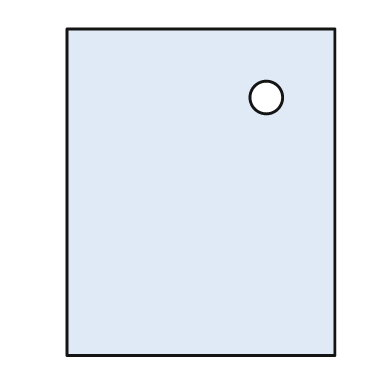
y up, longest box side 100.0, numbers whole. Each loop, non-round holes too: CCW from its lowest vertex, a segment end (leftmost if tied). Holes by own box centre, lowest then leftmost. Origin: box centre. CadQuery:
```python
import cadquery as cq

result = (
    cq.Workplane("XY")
    .moveTo(-41.0, -50.0)
    .lineTo(41.0, -50.0)
    .lineTo(41.0, 50.0)
    .lineTo(-41.0, 50.0)
    .close()
    .moveTo(20.0, 29.0)
    .circle(5.0)
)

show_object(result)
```